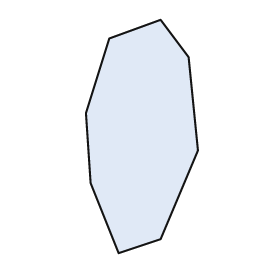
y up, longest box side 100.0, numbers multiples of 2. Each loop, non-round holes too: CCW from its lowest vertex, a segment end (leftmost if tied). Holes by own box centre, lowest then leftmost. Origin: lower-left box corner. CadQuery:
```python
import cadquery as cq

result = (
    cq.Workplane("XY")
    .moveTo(14.0, 0.0)
    .lineTo(32.0, 6.0)
    .lineTo(48.0, 44.0)
    .lineTo(44.0, 84.0)
    .lineTo(32.0, 100.0)
    .lineTo(10.0, 92.0)
    .lineTo(0.0, 60.0)
    .lineTo(2.0, 30.0)
    .close()
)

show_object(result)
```